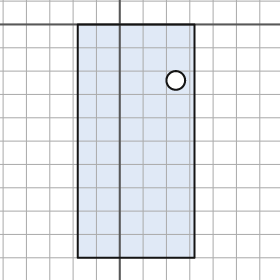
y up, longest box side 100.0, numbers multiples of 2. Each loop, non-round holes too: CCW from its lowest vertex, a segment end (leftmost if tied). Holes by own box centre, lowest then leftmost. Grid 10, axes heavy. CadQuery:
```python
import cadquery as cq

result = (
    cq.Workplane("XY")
    .moveTo(-18.0, -100.0)
    .lineTo(32.0, -100.0)
    .lineTo(32.0, 0.0)
    .lineTo(-18.0, 0.0)
    .close()
    .moveTo(24.0, -24.0)
    .circle(4.0)
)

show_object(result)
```